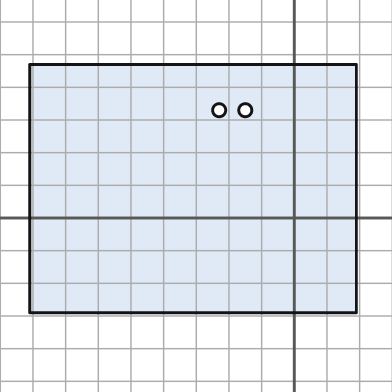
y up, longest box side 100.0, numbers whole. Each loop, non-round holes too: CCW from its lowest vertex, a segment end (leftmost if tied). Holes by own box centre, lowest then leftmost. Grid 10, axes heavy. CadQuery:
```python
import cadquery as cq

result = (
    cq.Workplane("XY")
    .moveTo(-81.0, -29.0)
    .lineTo(19.0, -29.0)
    .lineTo(19.0, 47.0)
    .lineTo(-81.0, 47.0)
    .close()
    .moveTo(-23.0, 33.0)
    .circle(2.0)
    .moveTo(-15.0, 33.0)
    .circle(2.0)
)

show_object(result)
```